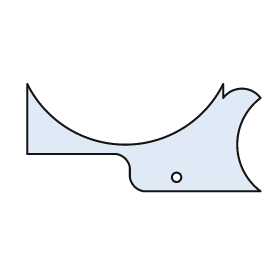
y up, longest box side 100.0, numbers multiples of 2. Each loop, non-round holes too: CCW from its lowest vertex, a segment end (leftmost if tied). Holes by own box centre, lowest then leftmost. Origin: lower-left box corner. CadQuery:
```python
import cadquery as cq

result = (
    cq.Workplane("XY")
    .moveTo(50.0, 0.0)
    .lineTo(100.0, 0.0)
    .threePointArc((90.0, 20.0), (100.0, 40.0))
    .threePointArc((92.0, 44.0), (84.0, 40.0))
    .lineTo(84.0, 46.0)
    .threePointArc((42.0, 20.0), (0.0, 46.0))
    .lineTo(0.0, 16.0)
    .lineTo(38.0, 16.0)
    .threePointArc((42.0, 14.0), (44.0, 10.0))
    .lineTo(44.0, 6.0)
    .threePointArc((46.0, 2.0), (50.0, 0.0))
    .close()
    .moveTo(64.0, 6.0)
    .circle(2.0)
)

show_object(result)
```